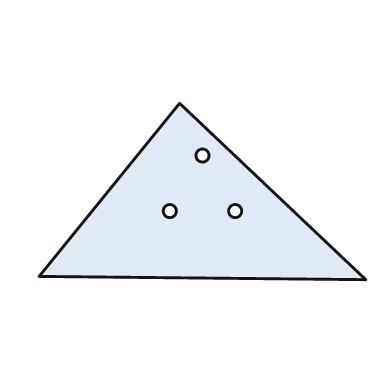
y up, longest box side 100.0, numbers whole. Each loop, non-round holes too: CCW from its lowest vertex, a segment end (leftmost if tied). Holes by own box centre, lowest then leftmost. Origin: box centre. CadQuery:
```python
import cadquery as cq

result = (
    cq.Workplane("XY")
    .moveTo(50.0, -27.0)
    .lineTo(-7.0, 27.0)
    .lineTo(-50.0, -26.0)
    .close()
    .moveTo(-10.0, -6.0)
    .circle(2.0)
    .moveTo(10.0, -6.0)
    .circle(2.0)
    .moveTo(0.0, 11.0)
    .circle(2.0)
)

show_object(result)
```